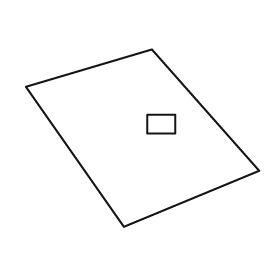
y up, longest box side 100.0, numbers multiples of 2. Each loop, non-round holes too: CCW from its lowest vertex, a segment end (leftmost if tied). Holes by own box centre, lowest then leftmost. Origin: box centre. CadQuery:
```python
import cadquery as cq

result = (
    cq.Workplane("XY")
    .moveTo(-8.0, -38.0)
    .lineTo(50.0, -14.0)
    .lineTo(4.0, 38.0)
    .lineTo(-50.0, 22.0)
    .close()
    .moveTo(2.0, 2.0)
    .lineTo(14.0, 2.0)
    .lineTo(14.0, 10.0)
    .lineTo(2.0, 10.0)
    .close()
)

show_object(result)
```